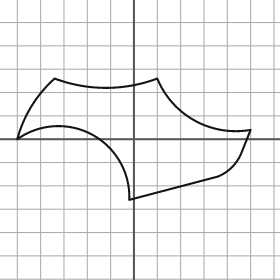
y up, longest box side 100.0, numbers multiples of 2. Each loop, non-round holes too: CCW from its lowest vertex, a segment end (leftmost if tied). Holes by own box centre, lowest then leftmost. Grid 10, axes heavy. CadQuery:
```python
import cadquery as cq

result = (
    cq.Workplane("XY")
    .moveTo(-2.0, -26.0)
    .lineTo(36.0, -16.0)
    .threePointArc((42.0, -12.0), (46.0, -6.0))
    .lineTo(50.0, 4.0)
    .threePointArc((26.0, 8.0), (10.0, 26.0))
    .threePointArc((-12.0, 22.0), (-34.0, 26.0))
    .threePointArc((-44.0, 14.0), (-50.0, 0.0))
    .threePointArc((-18.0, 2.0), (-2.0, -26.0))
    .close()
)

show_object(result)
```